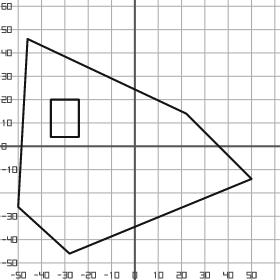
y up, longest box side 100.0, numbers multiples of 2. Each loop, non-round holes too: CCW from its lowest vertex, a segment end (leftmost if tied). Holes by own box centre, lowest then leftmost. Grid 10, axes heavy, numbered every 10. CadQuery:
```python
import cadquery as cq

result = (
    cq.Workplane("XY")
    .moveTo(-28.0, -46.0)
    .lineTo(50.0, -14.0)
    .lineTo(22.0, 14.0)
    .lineTo(-46.0, 46.0)
    .lineTo(-50.0, -26.0)
    .close()
    .moveTo(-36.0, 4.0)
    .lineTo(-24.0, 4.0)
    .lineTo(-24.0, 20.0)
    .lineTo(-36.0, 20.0)
    .close()
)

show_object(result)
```